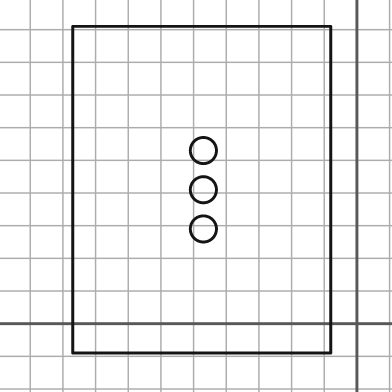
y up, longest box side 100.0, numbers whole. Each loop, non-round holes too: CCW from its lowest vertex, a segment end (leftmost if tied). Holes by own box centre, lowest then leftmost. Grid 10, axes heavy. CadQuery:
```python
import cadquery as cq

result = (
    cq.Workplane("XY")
    .moveTo(-87.0, -9.0)
    .lineTo(-8.0, -9.0)
    .lineTo(-8.0, 91.0)
    .lineTo(-87.0, 91.0)
    .close()
    .moveTo(-47.0, 29.0)
    .circle(4.0)
    .moveTo(-47.0, 41.0)
    .circle(4.0)
    .moveTo(-47.0, 53.0)
    .circle(4.0)
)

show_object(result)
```